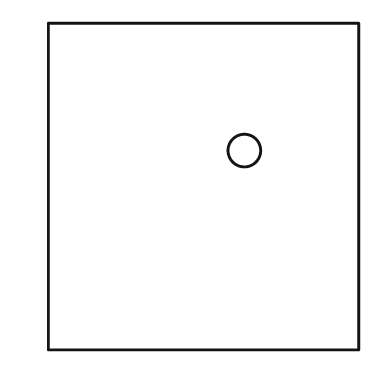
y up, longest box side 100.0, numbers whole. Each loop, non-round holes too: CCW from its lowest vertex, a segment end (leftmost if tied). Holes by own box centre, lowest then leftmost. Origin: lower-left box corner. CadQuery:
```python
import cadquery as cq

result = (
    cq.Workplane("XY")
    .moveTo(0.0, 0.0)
    .lineTo(95.0, 0.0)
    .lineTo(95.0, 100.0)
    .lineTo(0.0, 100.0)
    .close()
    .moveTo(60.0, 61.0)
    .circle(5.0)
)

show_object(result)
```